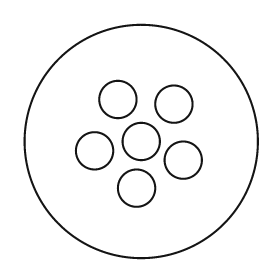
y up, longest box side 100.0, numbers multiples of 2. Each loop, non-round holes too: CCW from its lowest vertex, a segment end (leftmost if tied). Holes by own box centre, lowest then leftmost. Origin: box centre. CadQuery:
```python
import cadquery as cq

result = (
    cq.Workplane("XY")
    .moveTo(0.0, 0.0)
    .circle(50.0)
    .moveTo(-2.0, -20.0)
    .circle(8.0)
    .moveTo(18.0, -8.0)
    .circle(8.0)
    .moveTo(-20.0, -4.0)
    .circle(8.0)
    .moveTo(0.0, 0.0)
    .circle(8.0)
    .moveTo(14.0, 16.0)
    .circle(8.0)
    .moveTo(-10.0, 18.0)
    .circle(8.0)
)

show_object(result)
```